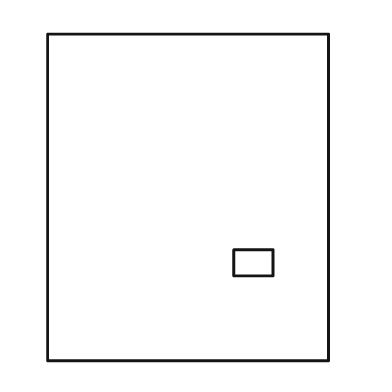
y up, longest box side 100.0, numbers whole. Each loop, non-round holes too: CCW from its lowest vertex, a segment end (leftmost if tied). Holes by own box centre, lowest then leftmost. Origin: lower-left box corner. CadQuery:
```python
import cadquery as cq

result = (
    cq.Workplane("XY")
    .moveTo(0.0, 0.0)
    .lineTo(86.0, 0.0)
    .lineTo(86.0, 100.0)
    .lineTo(0.0, 100.0)
    .close()
    .moveTo(57.0, 26.0)
    .lineTo(69.0, 26.0)
    .lineTo(69.0, 34.0)
    .lineTo(57.0, 34.0)
    .close()
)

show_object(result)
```